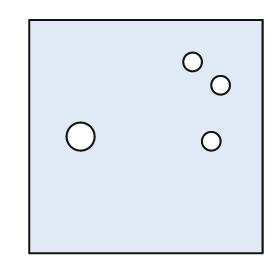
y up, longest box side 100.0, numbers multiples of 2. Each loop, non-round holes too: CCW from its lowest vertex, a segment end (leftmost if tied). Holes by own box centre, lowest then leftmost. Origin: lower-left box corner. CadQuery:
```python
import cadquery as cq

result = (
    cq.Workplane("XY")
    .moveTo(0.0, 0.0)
    .lineTo(100.0, 0.0)
    .lineTo(100.0, 100.0)
    .lineTo(0.0, 100.0)
    .close()
    .moveTo(78.0, 48.0)
    .circle(4.0)
    .moveTo(22.0, 50.0)
    .circle(6.0)
    .moveTo(82.0, 72.0)
    .circle(4.0)
    .moveTo(70.0, 82.0)
    .circle(4.0)
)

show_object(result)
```